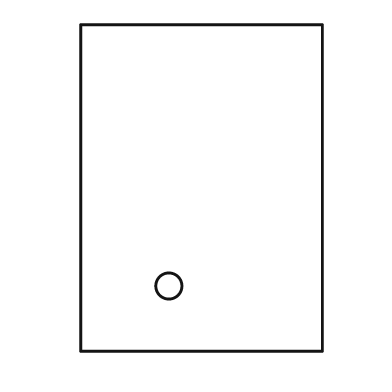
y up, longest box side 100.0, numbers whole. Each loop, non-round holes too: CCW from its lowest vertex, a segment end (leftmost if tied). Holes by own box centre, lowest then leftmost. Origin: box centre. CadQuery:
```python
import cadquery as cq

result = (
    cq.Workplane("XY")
    .moveTo(-37.0, -50.0)
    .lineTo(37.0, -50.0)
    .lineTo(37.0, 50.0)
    .lineTo(-37.0, 50.0)
    .close()
    .moveTo(-10.0, -30.0)
    .circle(4.0)
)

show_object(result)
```